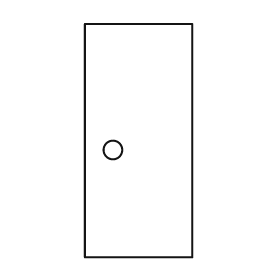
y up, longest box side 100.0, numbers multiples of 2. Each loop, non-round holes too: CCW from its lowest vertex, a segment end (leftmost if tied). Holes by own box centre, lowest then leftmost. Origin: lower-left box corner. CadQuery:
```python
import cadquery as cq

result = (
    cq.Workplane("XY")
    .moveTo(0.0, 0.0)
    .lineTo(46.0, 0.0)
    .lineTo(46.0, 100.0)
    .lineTo(0.0, 100.0)
    .close()
    .moveTo(12.0, 46.0)
    .circle(4.0)
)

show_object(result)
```